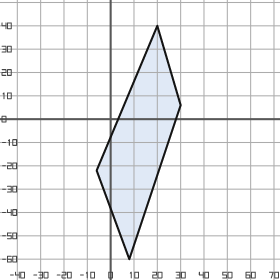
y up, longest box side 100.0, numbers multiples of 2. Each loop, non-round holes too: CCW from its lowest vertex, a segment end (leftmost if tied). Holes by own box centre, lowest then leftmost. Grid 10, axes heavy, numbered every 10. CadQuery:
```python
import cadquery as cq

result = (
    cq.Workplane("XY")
    .moveTo(8.0, -60.0)
    .lineTo(30.0, 6.0)
    .lineTo(20.0, 40.0)
    .lineTo(-6.0, -22.0)
    .close()
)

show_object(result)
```